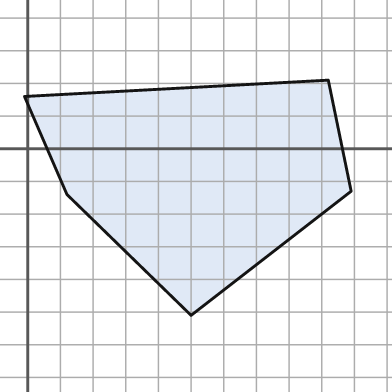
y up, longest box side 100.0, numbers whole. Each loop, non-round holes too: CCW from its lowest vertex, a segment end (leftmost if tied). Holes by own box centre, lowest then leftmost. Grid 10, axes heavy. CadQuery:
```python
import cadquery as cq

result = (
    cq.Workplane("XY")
    .moveTo(50.0, -51.0)
    .lineTo(99.0, -13.0)
    .lineTo(92.0, 21.0)
    .lineTo(-1.0, 16.0)
    .lineTo(12.0, -14.0)
    .close()
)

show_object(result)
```